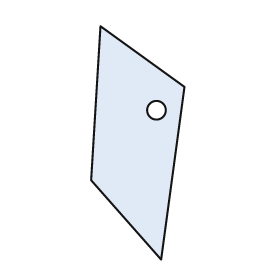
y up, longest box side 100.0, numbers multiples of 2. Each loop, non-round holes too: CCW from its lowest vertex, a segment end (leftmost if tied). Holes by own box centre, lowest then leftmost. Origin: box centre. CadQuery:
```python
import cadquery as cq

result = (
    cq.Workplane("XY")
    .moveTo(10.0, -50.0)
    .lineTo(20.0, 24.0)
    .lineTo(-16.0, 50.0)
    .lineTo(-20.0, -16.0)
    .close()
    .moveTo(8.0, 14.0)
    .circle(4.0)
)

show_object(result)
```